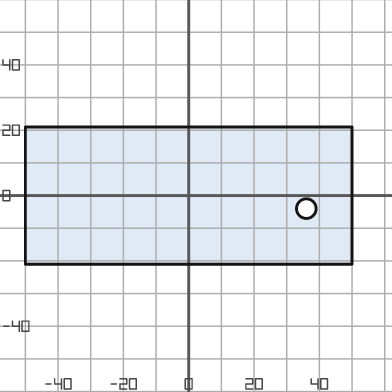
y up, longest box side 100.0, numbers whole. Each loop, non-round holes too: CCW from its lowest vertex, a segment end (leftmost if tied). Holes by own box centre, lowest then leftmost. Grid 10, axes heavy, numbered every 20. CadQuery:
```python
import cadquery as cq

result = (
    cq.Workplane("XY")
    .moveTo(-50.0, -21.0)
    .lineTo(50.0, -21.0)
    .lineTo(50.0, 21.0)
    .lineTo(-50.0, 21.0)
    .close()
    .moveTo(36.0, -4.0)
    .circle(3.0)
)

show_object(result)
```